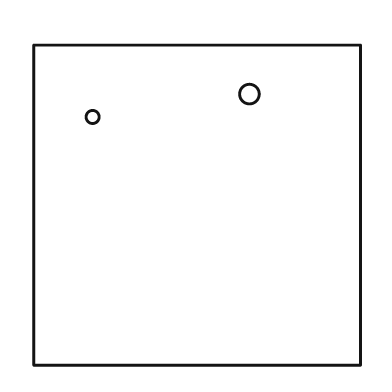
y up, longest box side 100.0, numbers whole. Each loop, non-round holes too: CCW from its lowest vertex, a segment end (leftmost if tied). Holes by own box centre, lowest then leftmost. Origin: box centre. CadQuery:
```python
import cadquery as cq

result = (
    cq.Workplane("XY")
    .moveTo(-50.0, -49.0)
    .lineTo(50.0, -49.0)
    .lineTo(50.0, 49.0)
    .lineTo(-50.0, 49.0)
    .close()
    .moveTo(-32.0, 27.0)
    .circle(2.0)
    .moveTo(16.0, 34.0)
    .circle(3.0)
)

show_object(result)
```